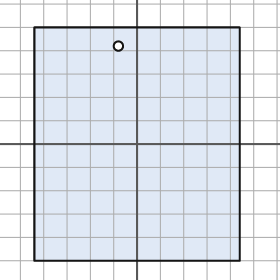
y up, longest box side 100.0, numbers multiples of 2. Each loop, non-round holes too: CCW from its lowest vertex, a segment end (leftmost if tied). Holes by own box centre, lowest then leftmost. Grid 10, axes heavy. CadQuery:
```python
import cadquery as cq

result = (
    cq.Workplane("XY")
    .moveTo(-44.0, -50.0)
    .lineTo(44.0, -50.0)
    .lineTo(44.0, 50.0)
    .lineTo(-44.0, 50.0)
    .close()
    .moveTo(-8.0, 42.0)
    .circle(2.0)
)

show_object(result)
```